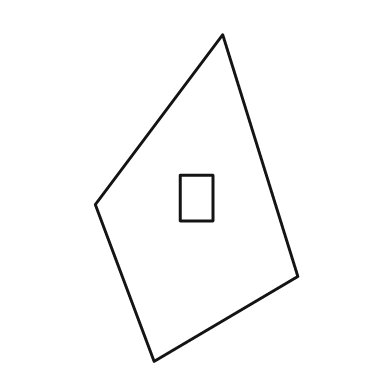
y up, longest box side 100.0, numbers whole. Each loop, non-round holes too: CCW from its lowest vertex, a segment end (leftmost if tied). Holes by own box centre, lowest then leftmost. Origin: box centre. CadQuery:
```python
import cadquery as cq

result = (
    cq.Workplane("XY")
    .moveTo(-13.0, -50.0)
    .lineTo(31.0, -24.0)
    .lineTo(8.0, 50.0)
    .lineTo(-31.0, -2.0)
    .close()
    .moveTo(-5.0, -7.0)
    .lineTo(5.0, -7.0)
    .lineTo(5.0, 7.0)
    .lineTo(-5.0, 7.0)
    .close()
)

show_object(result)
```